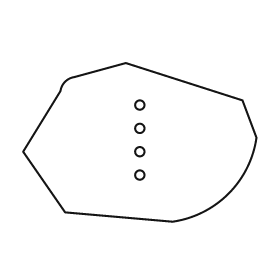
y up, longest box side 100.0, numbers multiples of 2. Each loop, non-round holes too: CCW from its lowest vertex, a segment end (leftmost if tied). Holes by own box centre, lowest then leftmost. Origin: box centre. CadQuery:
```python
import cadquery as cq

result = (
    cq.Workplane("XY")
    .moveTo(14.0, -34.0)
    .threePointArc((38.0, -22.0), (50.0, 2.0))
    .lineTo(44.0, 18.0)
    .lineTo(-6.0, 34.0)
    .lineTo(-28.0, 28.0)
    .threePointArc((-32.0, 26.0), (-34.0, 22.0))
    .lineTo(-50.0, -4.0)
    .lineTo(-32.0, -30.0)
    .close()
    .moveTo(0.0, -14.0)
    .circle(2.0)
    .moveTo(0.0, -4.0)
    .circle(2.0)
    .moveTo(0.0, 6.0)
    .circle(2.0)
    .moveTo(0.0, 16.0)
    .circle(2.0)
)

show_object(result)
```